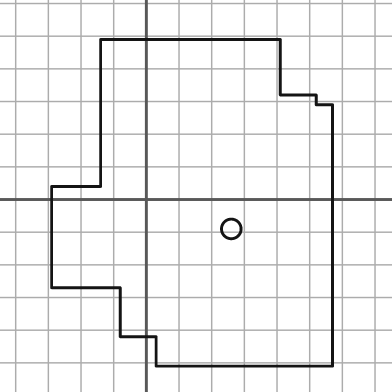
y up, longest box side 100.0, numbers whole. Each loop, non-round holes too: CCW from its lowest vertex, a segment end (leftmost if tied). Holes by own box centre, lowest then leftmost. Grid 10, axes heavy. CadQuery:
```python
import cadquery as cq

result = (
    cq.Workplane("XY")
    .moveTo(3.0, -51.0)
    .lineTo(57.0, -51.0)
    .lineTo(57.0, 29.0)
    .lineTo(52.0, 29.0)
    .lineTo(52.0, 32.0)
    .lineTo(41.0, 32.0)
    .lineTo(41.0, 49.0)
    .lineTo(-14.0, 49.0)
    .lineTo(-14.0, 4.0)
    .lineTo(-29.0, 4.0)
    .lineTo(-29.0, -27.0)
    .lineTo(-8.0, -27.0)
    .lineTo(-8.0, -42.0)
    .lineTo(3.0, -42.0)
    .close()
    .moveTo(26.0, -9.0)
    .circle(3.0)
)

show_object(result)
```